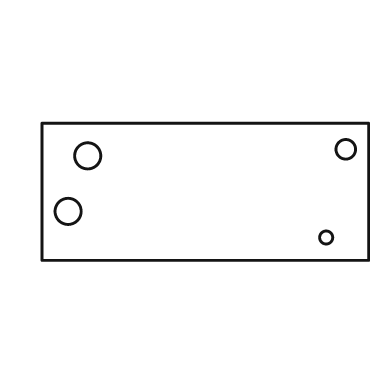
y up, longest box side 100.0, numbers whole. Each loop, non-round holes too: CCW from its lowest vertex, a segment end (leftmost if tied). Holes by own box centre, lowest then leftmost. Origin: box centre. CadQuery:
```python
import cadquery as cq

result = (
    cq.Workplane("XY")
    .moveTo(-50.0, -21.0)
    .lineTo(50.0, -21.0)
    .lineTo(50.0, 21.0)
    .lineTo(-50.0, 21.0)
    .close()
    .moveTo(37.0, -14.0)
    .circle(2.0)
    .moveTo(-42.0, -6.0)
    .circle(4.0)
    .moveTo(-36.0, 11.0)
    .circle(4.0)
    .moveTo(43.0, 13.0)
    .circle(3.0)
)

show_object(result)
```